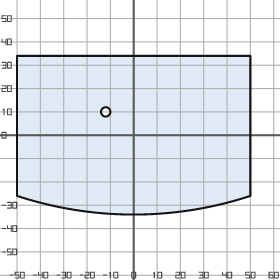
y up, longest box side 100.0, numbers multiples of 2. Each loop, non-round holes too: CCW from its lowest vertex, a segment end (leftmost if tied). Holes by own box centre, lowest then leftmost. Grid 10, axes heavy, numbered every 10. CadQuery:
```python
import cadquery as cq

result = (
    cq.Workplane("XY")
    .moveTo(-50.0, -26.0)
    .threePointArc((0.0, -34.0), (50.0, -26.0))
    .lineTo(50.0, 34.0)
    .lineTo(-50.0, 34.0)
    .close()
    .moveTo(-12.0, 10.0)
    .circle(2.0)
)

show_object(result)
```